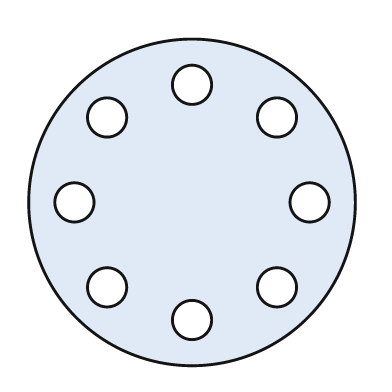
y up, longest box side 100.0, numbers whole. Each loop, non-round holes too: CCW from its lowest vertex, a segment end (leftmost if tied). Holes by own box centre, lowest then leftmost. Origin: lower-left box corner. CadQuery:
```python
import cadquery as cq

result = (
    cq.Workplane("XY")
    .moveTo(50.0, 50.0)
    .circle(50.0)
    .moveTo(50.0, 14.0)
    .circle(6.0)
    .moveTo(24.0, 24.0)
    .circle(6.0)
    .moveTo(76.0, 24.0)
    .circle(6.0)
    .moveTo(14.0, 50.0)
    .circle(6.0)
    .moveTo(86.0, 50.0)
    .circle(6.0)
    .moveTo(24.0, 76.0)
    .circle(6.0)
    .moveTo(76.0, 76.0)
    .circle(6.0)
    .moveTo(50.0, 86.0)
    .circle(6.0)
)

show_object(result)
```